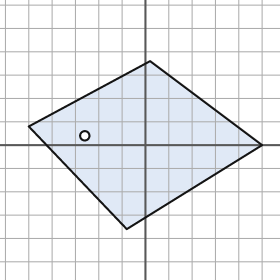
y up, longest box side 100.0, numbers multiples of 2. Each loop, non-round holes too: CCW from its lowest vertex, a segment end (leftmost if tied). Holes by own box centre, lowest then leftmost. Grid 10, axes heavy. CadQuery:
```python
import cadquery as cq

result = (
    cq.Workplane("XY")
    .moveTo(-8.0, -36.0)
    .lineTo(50.0, 0.0)
    .lineTo(2.0, 36.0)
    .lineTo(-50.0, 8.0)
    .close()
    .moveTo(-26.0, 4.0)
    .circle(2.0)
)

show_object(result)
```